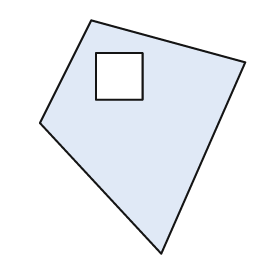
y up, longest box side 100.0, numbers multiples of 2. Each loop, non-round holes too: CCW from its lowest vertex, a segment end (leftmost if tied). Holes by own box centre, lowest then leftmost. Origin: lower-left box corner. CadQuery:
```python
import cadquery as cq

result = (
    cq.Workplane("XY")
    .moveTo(52.0, 0.0)
    .lineTo(88.0, 82.0)
    .lineTo(22.0, 100.0)
    .lineTo(0.0, 56.0)
    .close()
    .moveTo(24.0, 66.0)
    .lineTo(44.0, 66.0)
    .lineTo(44.0, 86.0)
    .lineTo(24.0, 86.0)
    .close()
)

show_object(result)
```